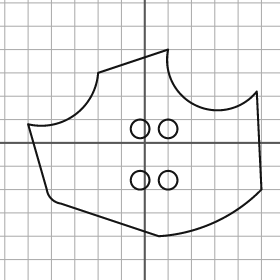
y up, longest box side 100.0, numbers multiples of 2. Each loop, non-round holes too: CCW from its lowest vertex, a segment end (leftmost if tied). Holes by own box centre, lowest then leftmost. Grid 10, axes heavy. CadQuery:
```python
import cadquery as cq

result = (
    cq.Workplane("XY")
    .moveTo(6.0, -40.0)
    .threePointArc((30.0, -34.0), (50.0, -20.0))
    .lineTo(48.0, 22.0)
    .threePointArc((22.0, 16.0), (10.0, 40.0))
    .lineTo(-20.0, 30.0)
    .threePointArc((-30.0, 12.0), (-50.0, 8.0))
    .lineTo(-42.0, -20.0)
    .threePointArc((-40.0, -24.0), (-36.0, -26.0))
    .close()
    .moveTo(-2.0, -16.0)
    .circle(4.0)
    .moveTo(10.0, -16.0)
    .circle(4.0)
    .moveTo(-2.0, 6.0)
    .circle(4.0)
    .moveTo(10.0, 6.0)
    .circle(4.0)
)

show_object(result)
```